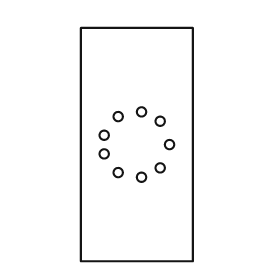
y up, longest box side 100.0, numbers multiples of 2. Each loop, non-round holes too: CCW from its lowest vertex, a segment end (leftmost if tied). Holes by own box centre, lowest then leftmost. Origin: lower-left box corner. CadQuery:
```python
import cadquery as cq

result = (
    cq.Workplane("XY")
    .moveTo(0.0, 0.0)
    .lineTo(48.0, 0.0)
    .lineTo(48.0, 100.0)
    .lineTo(0.0, 100.0)
    .close()
    .moveTo(26.0, 36.0)
    .circle(2.0)
    .moveTo(16.0, 38.0)
    .circle(2.0)
    .moveTo(34.0, 40.0)
    .circle(2.0)
    .moveTo(10.0, 46.0)
    .circle(2.0)
    .moveTo(38.0, 50.0)
    .circle(2.0)
    .moveTo(10.0, 54.0)
    .circle(2.0)
    .moveTo(34.0, 60.0)
    .circle(2.0)
    .moveTo(16.0, 62.0)
    .circle(2.0)
    .moveTo(26.0, 64.0)
    .circle(2.0)
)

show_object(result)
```